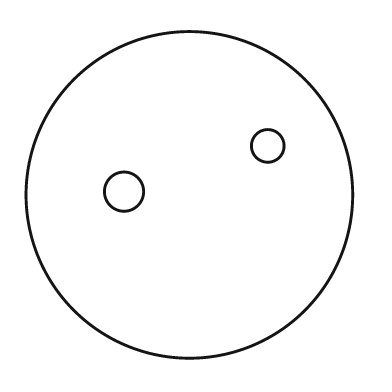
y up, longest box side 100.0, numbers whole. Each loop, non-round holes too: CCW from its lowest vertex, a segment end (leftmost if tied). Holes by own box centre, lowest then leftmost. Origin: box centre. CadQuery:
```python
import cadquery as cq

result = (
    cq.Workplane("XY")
    .moveTo(0.0, 0.0)
    .circle(50.0)
    .moveTo(-20.0, 1.0)
    .circle(6.0)
    .moveTo(24.0, 15.0)
    .circle(5.0)
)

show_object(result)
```